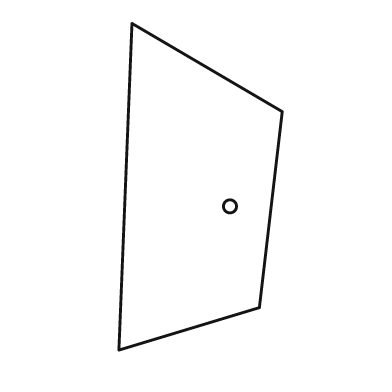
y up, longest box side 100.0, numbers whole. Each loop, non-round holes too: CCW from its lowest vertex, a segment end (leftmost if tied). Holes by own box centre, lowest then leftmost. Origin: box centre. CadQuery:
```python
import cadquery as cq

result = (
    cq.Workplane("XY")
    .moveTo(-25.0, -50.0)
    .lineTo(18.0, -37.0)
    .lineTo(25.0, 23.0)
    .lineTo(-21.0, 50.0)
    .close()
    .moveTo(9.0, -6.0)
    .circle(2.0)
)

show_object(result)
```